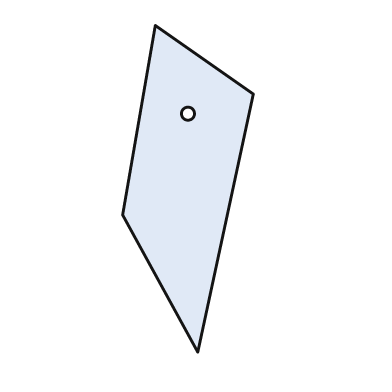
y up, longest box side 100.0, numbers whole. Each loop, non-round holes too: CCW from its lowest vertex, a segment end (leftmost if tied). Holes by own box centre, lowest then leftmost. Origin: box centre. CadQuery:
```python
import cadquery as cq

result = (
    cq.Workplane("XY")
    .moveTo(3.0, -50.0)
    .lineTo(20.0, 29.0)
    .lineTo(-10.0, 50.0)
    .lineTo(-20.0, -8.0)
    .close()
    .moveTo(0.0, 23.0)
    .circle(2.0)
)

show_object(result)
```